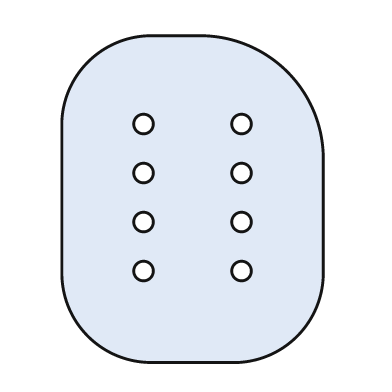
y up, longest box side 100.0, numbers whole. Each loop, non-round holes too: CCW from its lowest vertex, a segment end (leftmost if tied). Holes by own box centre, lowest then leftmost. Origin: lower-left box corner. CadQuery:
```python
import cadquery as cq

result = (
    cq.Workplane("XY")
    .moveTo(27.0, 0.0)
    .lineTo(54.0, 0.0)
    .threePointArc((72.0, 8.0), (80.0, 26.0))
    .lineTo(80.0, 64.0)
    .threePointArc((69.0, 89.0), (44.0, 100.0))
    .lineTo(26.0, 100.0)
    .threePointArc((8.0, 92.0), (0.0, 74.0))
    .lineTo(0.0, 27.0)
    .threePointArc((8.0, 8.0), (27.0, 0.0))
    .close()
    .moveTo(25.0, 28.0)
    .circle(3.0)
    .moveTo(55.0, 28.0)
    .circle(3.0)
    .moveTo(25.0, 43.0)
    .circle(3.0)
    .moveTo(55.0, 43.0)
    .circle(3.0)
    .moveTo(25.0, 58.0)
    .circle(3.0)
    .moveTo(55.0, 58.0)
    .circle(3.0)
    .moveTo(25.0, 73.0)
    .circle(3.0)
    .moveTo(55.0, 73.0)
    .circle(3.0)
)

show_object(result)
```